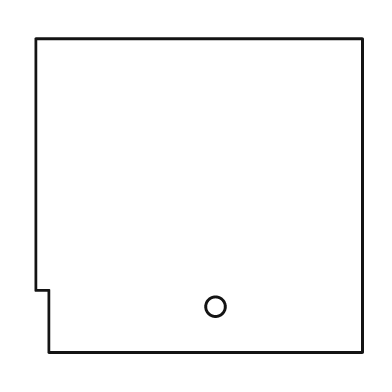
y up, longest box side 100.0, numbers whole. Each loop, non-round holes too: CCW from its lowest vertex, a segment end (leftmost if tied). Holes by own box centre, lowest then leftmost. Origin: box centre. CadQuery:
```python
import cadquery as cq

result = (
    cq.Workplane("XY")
    .moveTo(-46.0, -48.0)
    .lineTo(50.0, -48.0)
    .lineTo(50.0, 48.0)
    .lineTo(-50.0, 48.0)
    .lineTo(-50.0, -29.0)
    .lineTo(-46.0, -29.0)
    .close()
    .moveTo(5.0, -34.0)
    .circle(3.0)
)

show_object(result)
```